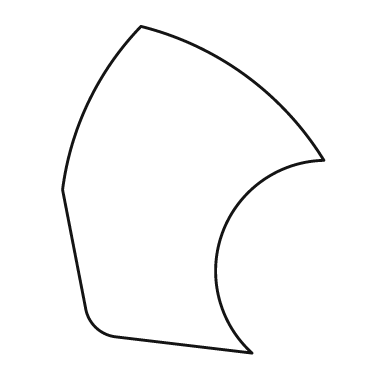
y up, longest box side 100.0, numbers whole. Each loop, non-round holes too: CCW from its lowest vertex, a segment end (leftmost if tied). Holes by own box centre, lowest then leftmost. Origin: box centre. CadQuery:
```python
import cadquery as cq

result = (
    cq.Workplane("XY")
    .moveTo(18.0, -50.0)
    .threePointArc((9.0, -13.0), (40.0, 9.0))
    .threePointArc((16.0, 35.0), (-16.0, 50.0))
    .threePointArc((-32.0, 27.0), (-40.0, 0.0))
    .lineTo(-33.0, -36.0)
    .threePointArc((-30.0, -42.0), (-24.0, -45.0))
    .close()
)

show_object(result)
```